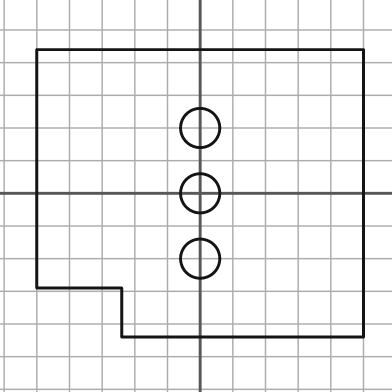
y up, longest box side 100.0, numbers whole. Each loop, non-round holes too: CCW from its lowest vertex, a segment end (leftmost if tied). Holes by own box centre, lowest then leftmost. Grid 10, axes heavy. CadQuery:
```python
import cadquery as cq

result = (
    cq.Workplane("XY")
    .moveTo(-24.0, -44.0)
    .lineTo(50.0, -44.0)
    .lineTo(50.0, 44.0)
    .lineTo(-50.0, 44.0)
    .lineTo(-50.0, -29.0)
    .lineTo(-24.0, -29.0)
    .close()
    .moveTo(0.0, -20.0)
    .circle(6.0)
    .moveTo(0.0, 0.0)
    .circle(6.0)
    .moveTo(0.0, 20.0)
    .circle(6.0)
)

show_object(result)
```